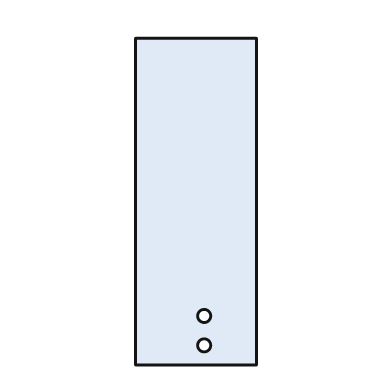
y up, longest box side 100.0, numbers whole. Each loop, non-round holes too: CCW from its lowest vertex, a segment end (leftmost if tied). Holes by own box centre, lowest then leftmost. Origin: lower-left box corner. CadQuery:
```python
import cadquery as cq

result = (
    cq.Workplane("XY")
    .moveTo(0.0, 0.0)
    .lineTo(37.0, 0.0)
    .lineTo(37.0, 100.0)
    .lineTo(0.0, 100.0)
    .close()
    .moveTo(21.0, 6.0)
    .circle(2.0)
    .moveTo(21.0, 15.0)
    .circle(2.0)
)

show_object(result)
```